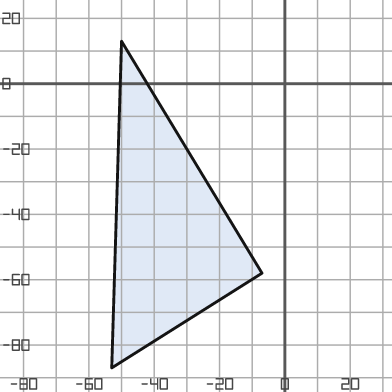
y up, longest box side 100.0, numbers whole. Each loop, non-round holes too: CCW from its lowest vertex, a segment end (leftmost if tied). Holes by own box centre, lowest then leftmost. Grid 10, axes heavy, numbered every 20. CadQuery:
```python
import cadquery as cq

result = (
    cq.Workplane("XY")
    .moveTo(-53.0, -87.0)
    .lineTo(-7.0, -58.0)
    .lineTo(-50.0, 13.0)
    .close()
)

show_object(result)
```